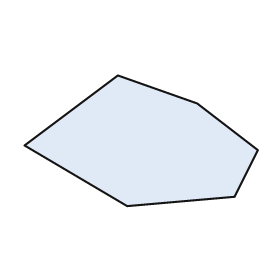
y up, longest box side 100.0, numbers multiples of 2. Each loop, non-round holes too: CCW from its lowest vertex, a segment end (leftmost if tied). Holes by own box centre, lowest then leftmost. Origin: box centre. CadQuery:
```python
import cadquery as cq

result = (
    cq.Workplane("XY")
    .moveTo(-6.0, -28.0)
    .lineTo(40.0, -24.0)
    .lineTo(50.0, -4.0)
    .lineTo(24.0, 16.0)
    .lineTo(-10.0, 28.0)
    .lineTo(-50.0, -2.0)
    .close()
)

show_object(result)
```